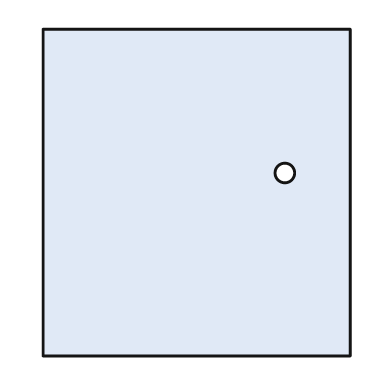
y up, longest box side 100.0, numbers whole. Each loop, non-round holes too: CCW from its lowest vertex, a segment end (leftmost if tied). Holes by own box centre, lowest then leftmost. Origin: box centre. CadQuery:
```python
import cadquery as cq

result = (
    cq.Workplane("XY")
    .moveTo(-47.0, -50.0)
    .lineTo(47.0, -50.0)
    .lineTo(47.0, 50.0)
    .lineTo(-47.0, 50.0)
    .close()
    .moveTo(27.0, 6.0)
    .circle(3.0)
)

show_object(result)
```